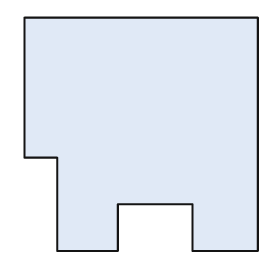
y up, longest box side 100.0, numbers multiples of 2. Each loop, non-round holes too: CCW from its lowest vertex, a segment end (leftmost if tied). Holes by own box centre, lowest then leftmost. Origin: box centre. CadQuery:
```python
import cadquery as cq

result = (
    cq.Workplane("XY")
    .moveTo(-36.0, -50.0)
    .lineTo(-10.0, -50.0)
    .lineTo(-10.0, -30.0)
    .lineTo(22.0, -30.0)
    .lineTo(22.0, -50.0)
    .lineTo(50.0, -50.0)
    .lineTo(50.0, 50.0)
    .lineTo(-50.0, 50.0)
    .lineTo(-50.0, -10.0)
    .lineTo(-36.0, -10.0)
    .close()
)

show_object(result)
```